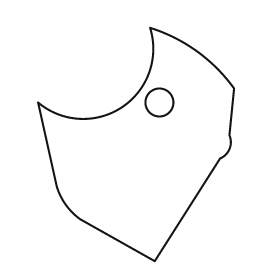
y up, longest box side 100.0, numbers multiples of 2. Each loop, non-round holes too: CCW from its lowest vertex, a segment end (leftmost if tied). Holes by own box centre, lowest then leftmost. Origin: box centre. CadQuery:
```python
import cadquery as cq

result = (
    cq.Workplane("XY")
    .moveTo(8.0, -50.0)
    .lineTo(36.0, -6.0)
    .threePointArc((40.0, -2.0), (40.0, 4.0))
    .lineTo(42.0, 24.0)
    .threePointArc((26.0, 40.0), (6.0, 50.0))
    .threePointArc((-6.0, 16.0), (-42.0, 18.0))
    .lineTo(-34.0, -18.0)
    .threePointArc((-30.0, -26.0), (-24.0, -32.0))
    .close()
    .moveTo(10.0, 18.0)
    .circle(6.0)
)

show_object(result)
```